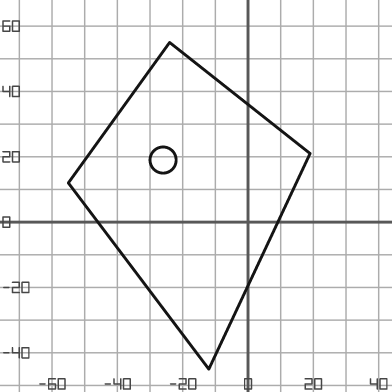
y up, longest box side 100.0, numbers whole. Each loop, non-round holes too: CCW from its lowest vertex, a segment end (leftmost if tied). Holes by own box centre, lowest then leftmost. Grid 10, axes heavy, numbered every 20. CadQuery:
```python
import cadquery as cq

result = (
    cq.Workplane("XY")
    .moveTo(-12.0, -45.0)
    .lineTo(19.0, 21.0)
    .lineTo(-24.0, 55.0)
    .lineTo(-55.0, 12.0)
    .close()
    .moveTo(-26.0, 19.0)
    .circle(4.0)
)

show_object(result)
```